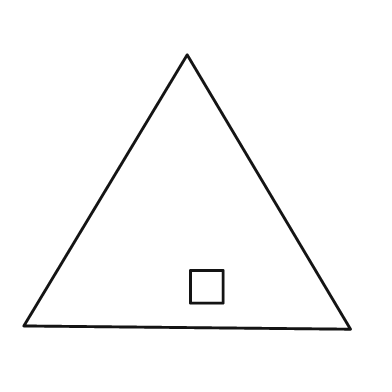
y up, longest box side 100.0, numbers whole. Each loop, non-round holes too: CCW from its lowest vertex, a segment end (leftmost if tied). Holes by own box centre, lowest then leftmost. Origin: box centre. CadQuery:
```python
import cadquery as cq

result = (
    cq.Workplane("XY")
    .moveTo(50.0, -42.0)
    .lineTo(0.0, 42.0)
    .lineTo(-50.0, -41.0)
    .close()
    .moveTo(1.0, -34.0)
    .lineTo(11.0, -34.0)
    .lineTo(11.0, -24.0)
    .lineTo(1.0, -24.0)
    .close()
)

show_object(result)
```